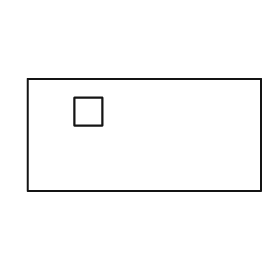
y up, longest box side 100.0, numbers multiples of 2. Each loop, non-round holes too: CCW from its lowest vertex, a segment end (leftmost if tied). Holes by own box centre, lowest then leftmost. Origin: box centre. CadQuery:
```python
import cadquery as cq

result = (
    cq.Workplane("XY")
    .moveTo(-50.0, -24.0)
    .lineTo(50.0, -24.0)
    .lineTo(50.0, 24.0)
    .lineTo(-50.0, 24.0)
    .close()
    .moveTo(-30.0, 4.0)
    .lineTo(-18.0, 4.0)
    .lineTo(-18.0, 16.0)
    .lineTo(-30.0, 16.0)
    .close()
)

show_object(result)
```